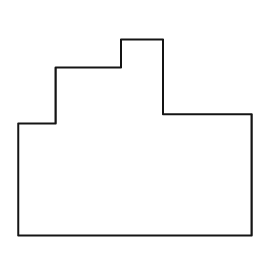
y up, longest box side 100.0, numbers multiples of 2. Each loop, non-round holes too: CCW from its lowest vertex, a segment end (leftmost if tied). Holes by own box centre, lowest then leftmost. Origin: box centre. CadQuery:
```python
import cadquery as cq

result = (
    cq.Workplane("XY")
    .moveTo(-50.0, -42.0)
    .lineTo(50.0, -42.0)
    .lineTo(50.0, 10.0)
    .lineTo(12.0, 10.0)
    .lineTo(12.0, 42.0)
    .lineTo(-6.0, 42.0)
    .lineTo(-6.0, 30.0)
    .lineTo(-34.0, 30.0)
    .lineTo(-34.0, 6.0)
    .lineTo(-50.0, 6.0)
    .close()
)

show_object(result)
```